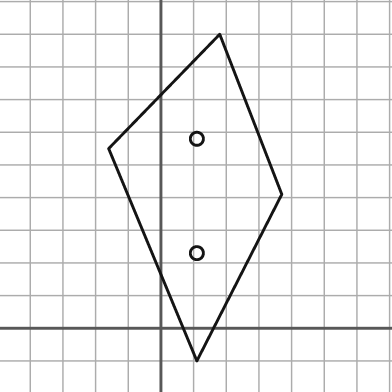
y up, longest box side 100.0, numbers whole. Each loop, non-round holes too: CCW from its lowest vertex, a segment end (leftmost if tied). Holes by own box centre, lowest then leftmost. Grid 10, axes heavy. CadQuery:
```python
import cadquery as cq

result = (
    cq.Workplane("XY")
    .moveTo(11.0, -10.0)
    .lineTo(37.0, 41.0)
    .lineTo(18.0, 90.0)
    .lineTo(-16.0, 55.0)
    .close()
    .moveTo(11.0, 23.0)
    .circle(2.0)
    .moveTo(11.0, 58.0)
    .circle(2.0)
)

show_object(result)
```